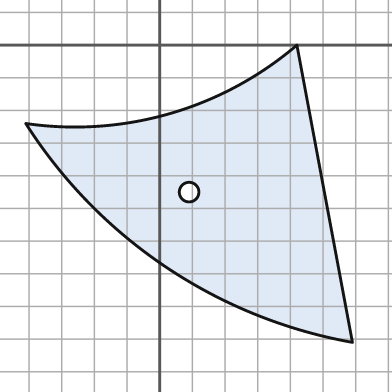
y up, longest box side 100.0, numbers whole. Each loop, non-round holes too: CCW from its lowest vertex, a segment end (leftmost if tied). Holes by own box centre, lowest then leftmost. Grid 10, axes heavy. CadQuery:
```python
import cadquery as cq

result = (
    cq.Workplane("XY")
    .moveTo(59.0, -91.0)
    .lineTo(42.0, 0.0)
    .threePointArc((3.0, -21.0), (-41.0, -24.0))
    .threePointArc((2.0, -68.0), (59.0, -91.0))
    .close()
    .moveTo(9.0, -45.0)
    .circle(3.0)
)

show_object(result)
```